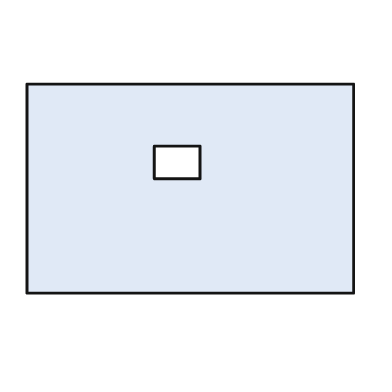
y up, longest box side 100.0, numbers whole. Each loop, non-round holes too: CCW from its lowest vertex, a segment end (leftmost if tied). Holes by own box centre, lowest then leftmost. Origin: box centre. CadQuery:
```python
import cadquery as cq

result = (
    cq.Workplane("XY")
    .moveTo(-50.0, -32.0)
    .lineTo(50.0, -32.0)
    .lineTo(50.0, 32.0)
    .lineTo(-50.0, 32.0)
    .close()
    .moveTo(-11.0, 3.0)
    .lineTo(3.0, 3.0)
    .lineTo(3.0, 13.0)
    .lineTo(-11.0, 13.0)
    .close()
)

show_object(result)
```